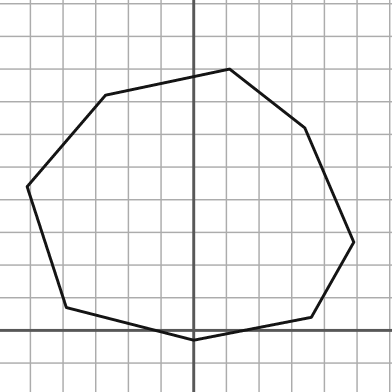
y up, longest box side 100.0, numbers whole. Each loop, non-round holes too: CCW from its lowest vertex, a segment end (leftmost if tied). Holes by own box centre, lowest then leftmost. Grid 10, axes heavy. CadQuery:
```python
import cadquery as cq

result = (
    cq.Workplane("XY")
    .moveTo(0.0, -3.0)
    .lineTo(36.0, 4.0)
    .lineTo(49.0, 27.0)
    .lineTo(34.0, 62.0)
    .lineTo(11.0, 80.0)
    .lineTo(-27.0, 72.0)
    .lineTo(-51.0, 44.0)
    .lineTo(-39.0, 7.0)
    .close()
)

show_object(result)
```